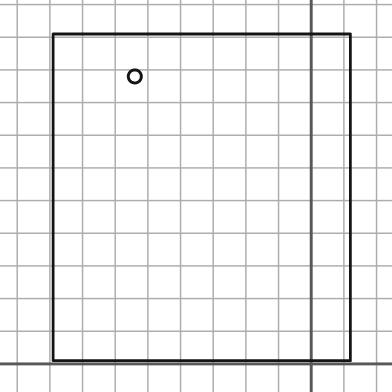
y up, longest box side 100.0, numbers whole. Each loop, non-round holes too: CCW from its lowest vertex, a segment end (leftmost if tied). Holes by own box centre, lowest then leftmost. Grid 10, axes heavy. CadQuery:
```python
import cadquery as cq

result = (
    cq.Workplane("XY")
    .moveTo(-79.0, 1.0)
    .lineTo(12.0, 1.0)
    .lineTo(12.0, 101.0)
    .lineTo(-79.0, 101.0)
    .close()
    .moveTo(-54.0, 88.0)
    .circle(2.0)
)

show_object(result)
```